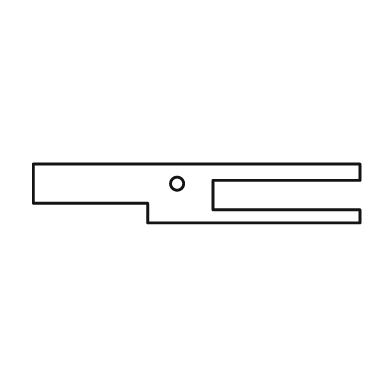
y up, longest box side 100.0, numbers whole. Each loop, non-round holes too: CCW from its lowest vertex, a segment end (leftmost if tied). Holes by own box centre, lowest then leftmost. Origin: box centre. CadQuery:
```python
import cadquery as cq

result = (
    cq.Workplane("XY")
    .moveTo(-15.0, -9.0)
    .lineTo(50.0, -9.0)
    .lineTo(50.0, -5.0)
    .lineTo(5.0, -5.0)
    .lineTo(5.0, 4.0)
    .lineTo(50.0, 4.0)
    .lineTo(50.0, 9.0)
    .lineTo(-50.0, 9.0)
    .lineTo(-50.0, -3.0)
    .lineTo(-15.0, -3.0)
    .close()
    .moveTo(-6.0, 3.0)
    .circle(2.0)
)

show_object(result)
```